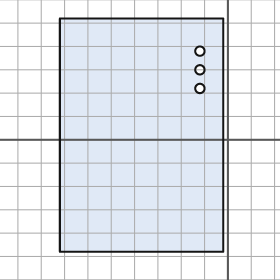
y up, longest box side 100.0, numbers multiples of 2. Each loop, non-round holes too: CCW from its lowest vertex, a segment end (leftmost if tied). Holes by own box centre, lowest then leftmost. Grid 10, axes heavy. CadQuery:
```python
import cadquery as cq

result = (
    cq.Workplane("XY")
    .moveTo(-72.0, -48.0)
    .lineTo(-2.0, -48.0)
    .lineTo(-2.0, 52.0)
    .lineTo(-72.0, 52.0)
    .close()
    .moveTo(-12.0, 22.0)
    .circle(2.0)
    .moveTo(-12.0, 30.0)
    .circle(2.0)
    .moveTo(-12.0, 38.0)
    .circle(2.0)
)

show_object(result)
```